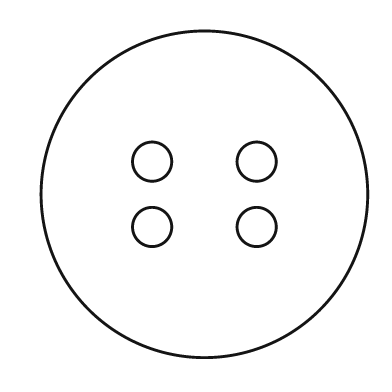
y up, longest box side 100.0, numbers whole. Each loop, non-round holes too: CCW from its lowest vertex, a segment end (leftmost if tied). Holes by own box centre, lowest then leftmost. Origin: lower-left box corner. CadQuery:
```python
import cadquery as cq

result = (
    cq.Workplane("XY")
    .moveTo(50.0, 50.0)
    .circle(50.0)
    .moveTo(34.0, 40.0)
    .circle(6.0)
    .moveTo(66.0, 40.0)
    .circle(6.0)
    .moveTo(34.0, 60.0)
    .circle(6.0)
    .moveTo(66.0, 60.0)
    .circle(6.0)
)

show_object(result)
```